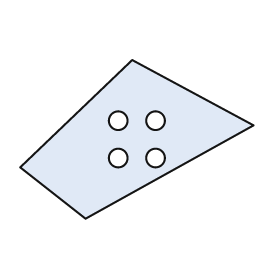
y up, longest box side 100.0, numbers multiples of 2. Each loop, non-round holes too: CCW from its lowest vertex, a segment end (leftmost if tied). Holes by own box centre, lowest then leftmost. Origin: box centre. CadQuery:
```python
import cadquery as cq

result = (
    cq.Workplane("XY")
    .moveTo(-22.0, -34.0)
    .lineTo(50.0, 6.0)
    .lineTo(-2.0, 34.0)
    .lineTo(-50.0, -12.0)
    .close()
    .moveTo(-8.0, -8.0)
    .circle(4.0)
    .moveTo(8.0, -8.0)
    .circle(4.0)
    .moveTo(-8.0, 8.0)
    .circle(4.0)
    .moveTo(8.0, 8.0)
    .circle(4.0)
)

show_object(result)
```